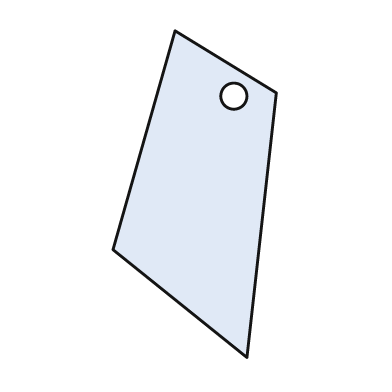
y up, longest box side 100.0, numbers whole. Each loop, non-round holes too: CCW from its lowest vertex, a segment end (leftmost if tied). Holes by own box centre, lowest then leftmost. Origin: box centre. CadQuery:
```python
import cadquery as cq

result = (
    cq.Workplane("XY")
    .moveTo(16.0, -50.0)
    .lineTo(25.0, 31.0)
    .lineTo(-6.0, 50.0)
    .lineTo(-25.0, -17.0)
    .close()
    .moveTo(12.0, 30.0)
    .circle(4.0)
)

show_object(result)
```